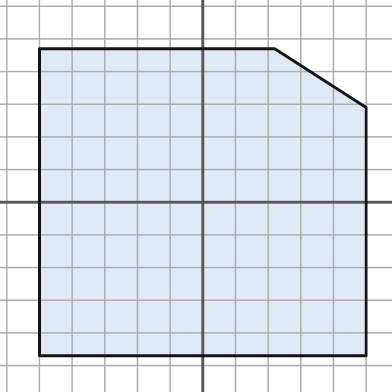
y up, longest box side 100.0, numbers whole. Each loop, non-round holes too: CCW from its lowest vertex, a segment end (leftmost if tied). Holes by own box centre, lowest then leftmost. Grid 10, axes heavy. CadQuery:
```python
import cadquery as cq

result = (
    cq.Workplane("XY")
    .moveTo(-50.0, -47.0)
    .lineTo(50.0, -47.0)
    .lineTo(50.0, 29.0)
    .lineTo(22.0, 47.0)
    .lineTo(-50.0, 47.0)
    .close()
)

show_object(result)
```